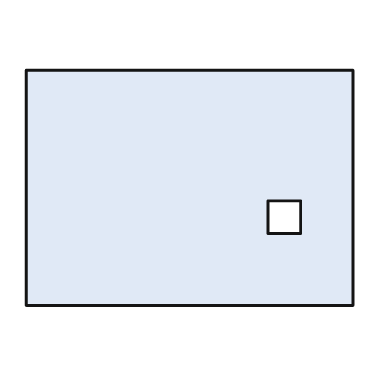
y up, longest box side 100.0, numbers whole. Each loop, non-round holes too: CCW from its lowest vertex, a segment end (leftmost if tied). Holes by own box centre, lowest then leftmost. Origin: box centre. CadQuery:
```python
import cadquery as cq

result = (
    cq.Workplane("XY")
    .moveTo(-50.0, -36.0)
    .lineTo(50.0, -36.0)
    .lineTo(50.0, 36.0)
    .lineTo(-50.0, 36.0)
    .close()
    .moveTo(24.0, -14.0)
    .lineTo(34.0, -14.0)
    .lineTo(34.0, -4.0)
    .lineTo(24.0, -4.0)
    .close()
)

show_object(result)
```